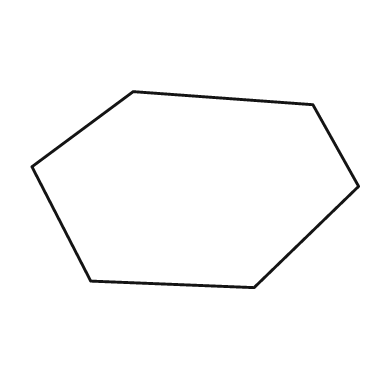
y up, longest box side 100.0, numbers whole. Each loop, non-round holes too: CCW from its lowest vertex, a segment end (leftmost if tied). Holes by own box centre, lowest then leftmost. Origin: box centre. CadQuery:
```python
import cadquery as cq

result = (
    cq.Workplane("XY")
    .moveTo(18.0, -30.0)
    .lineTo(50.0, 1.0)
    .lineTo(36.0, 26.0)
    .lineTo(-19.0, 30.0)
    .lineTo(-50.0, 7.0)
    .lineTo(-32.0, -28.0)
    .close()
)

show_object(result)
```